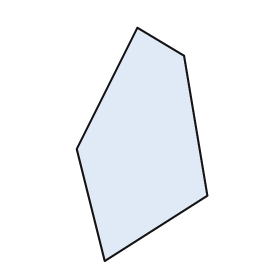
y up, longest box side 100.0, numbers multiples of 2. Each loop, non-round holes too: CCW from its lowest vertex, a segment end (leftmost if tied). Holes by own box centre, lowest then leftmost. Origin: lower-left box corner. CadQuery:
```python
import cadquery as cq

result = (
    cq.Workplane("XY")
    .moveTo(12.0, 0.0)
    .lineTo(56.0, 28.0)
    .lineTo(46.0, 88.0)
    .lineTo(26.0, 100.0)
    .lineTo(0.0, 48.0)
    .close()
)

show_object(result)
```